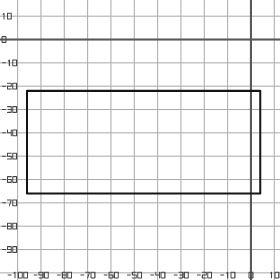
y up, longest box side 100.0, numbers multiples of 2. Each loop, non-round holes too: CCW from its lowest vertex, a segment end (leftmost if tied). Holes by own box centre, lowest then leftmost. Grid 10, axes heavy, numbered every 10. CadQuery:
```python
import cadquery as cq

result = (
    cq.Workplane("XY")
    .moveTo(-96.0, -66.0)
    .lineTo(4.0, -66.0)
    .lineTo(4.0, -22.0)
    .lineTo(-96.0, -22.0)
    .close()
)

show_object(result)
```